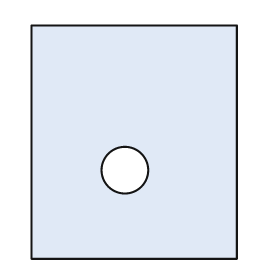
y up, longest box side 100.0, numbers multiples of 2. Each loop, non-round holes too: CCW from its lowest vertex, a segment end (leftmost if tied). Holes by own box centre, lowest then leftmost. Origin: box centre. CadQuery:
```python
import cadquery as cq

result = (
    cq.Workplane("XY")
    .moveTo(-44.0, -50.0)
    .lineTo(44.0, -50.0)
    .lineTo(44.0, 50.0)
    .lineTo(-44.0, 50.0)
    .close()
    .moveTo(-4.0, -12.0)
    .circle(10.0)
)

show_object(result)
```